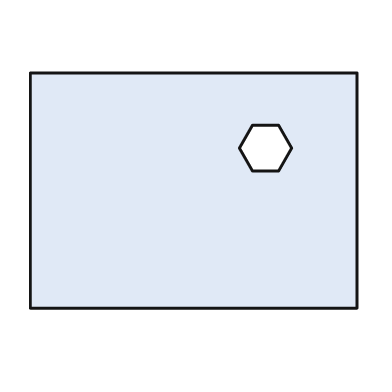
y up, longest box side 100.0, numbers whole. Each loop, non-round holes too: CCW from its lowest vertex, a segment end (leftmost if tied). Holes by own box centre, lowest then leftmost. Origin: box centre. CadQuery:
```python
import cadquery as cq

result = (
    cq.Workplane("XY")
    .moveTo(-50.0, -36.0)
    .lineTo(50.0, -36.0)
    .lineTo(50.0, 36.0)
    .lineTo(-50.0, 36.0)
    .close()
    .moveTo(18.0, 6.0)
    .lineTo(26.0, 6.0)
    .lineTo(30.0, 13.0)
    .lineTo(26.0, 20.0)
    .lineTo(18.0, 20.0)
    .lineTo(14.0, 13.0)
    .close()
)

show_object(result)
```